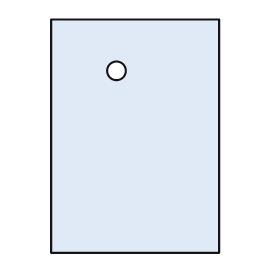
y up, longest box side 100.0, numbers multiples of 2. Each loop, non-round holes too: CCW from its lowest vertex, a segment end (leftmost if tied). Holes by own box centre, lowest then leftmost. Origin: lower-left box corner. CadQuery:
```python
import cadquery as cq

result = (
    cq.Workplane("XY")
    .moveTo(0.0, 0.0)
    .lineTo(72.0, 0.0)
    .lineTo(72.0, 100.0)
    .lineTo(0.0, 100.0)
    .close()
    .moveTo(28.0, 78.0)
    .circle(4.0)
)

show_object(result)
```